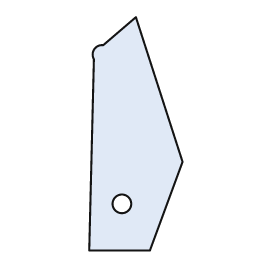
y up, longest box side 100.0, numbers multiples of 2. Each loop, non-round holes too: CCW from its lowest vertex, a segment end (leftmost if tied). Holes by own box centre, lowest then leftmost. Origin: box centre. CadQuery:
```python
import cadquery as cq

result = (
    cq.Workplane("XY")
    .moveTo(-20.0, -50.0)
    .lineTo(6.0, -50.0)
    .lineTo(20.0, -12.0)
    .lineTo(0.0, 50.0)
    .lineTo(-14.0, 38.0)
    .threePointArc((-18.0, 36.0), (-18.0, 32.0))
    .close()
    .moveTo(-6.0, -30.0)
    .circle(4.0)
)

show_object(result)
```